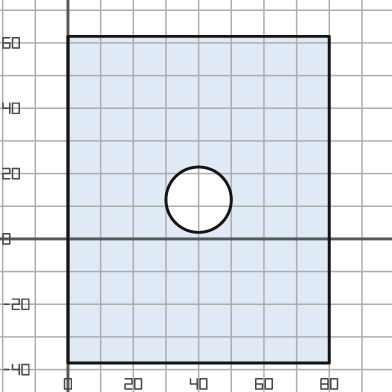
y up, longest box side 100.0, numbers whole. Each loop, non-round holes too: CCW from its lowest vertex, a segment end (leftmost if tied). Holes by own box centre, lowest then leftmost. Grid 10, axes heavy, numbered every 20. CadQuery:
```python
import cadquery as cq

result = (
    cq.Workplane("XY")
    .moveTo(0.0, -38.0)
    .lineTo(80.0, -38.0)
    .lineTo(80.0, 62.0)
    .lineTo(0.0, 62.0)
    .close()
    .moveTo(40.0, 12.0)
    .circle(10.0)
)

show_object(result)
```